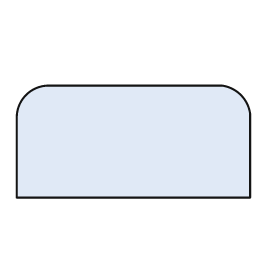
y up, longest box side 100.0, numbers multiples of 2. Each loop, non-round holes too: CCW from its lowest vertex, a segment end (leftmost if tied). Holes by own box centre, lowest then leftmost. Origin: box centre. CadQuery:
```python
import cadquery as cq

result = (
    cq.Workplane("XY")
    .moveTo(-50.0, -24.0)
    .lineTo(50.0, -24.0)
    .lineTo(50.0, 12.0)
    .threePointArc((46.0, 20.0), (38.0, 24.0))
    .lineTo(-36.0, 24.0)
    .threePointArc((-46.0, 20.0), (-50.0, 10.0))
    .close()
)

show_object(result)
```